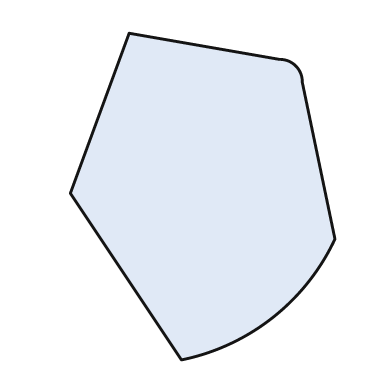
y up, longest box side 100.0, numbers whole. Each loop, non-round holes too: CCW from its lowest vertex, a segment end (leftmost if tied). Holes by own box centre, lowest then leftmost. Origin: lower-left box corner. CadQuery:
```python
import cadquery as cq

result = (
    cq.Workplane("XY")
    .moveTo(34.0, 0.0)
    .threePointArc((62.0, 13.0), (81.0, 37.0))
    .lineTo(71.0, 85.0)
    .threePointArc((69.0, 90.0), (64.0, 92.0))
    .lineTo(18.0, 100.0)
    .lineTo(0.0, 51.0)
    .close()
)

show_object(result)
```